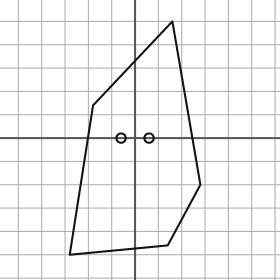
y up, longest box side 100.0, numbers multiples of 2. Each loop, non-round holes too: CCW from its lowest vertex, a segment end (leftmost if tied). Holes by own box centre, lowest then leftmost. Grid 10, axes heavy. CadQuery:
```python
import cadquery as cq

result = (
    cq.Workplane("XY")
    .moveTo(-28.0, -50.0)
    .lineTo(14.0, -46.0)
    .lineTo(28.0, -20.0)
    .lineTo(16.0, 50.0)
    .lineTo(-18.0, 14.0)
    .close()
    .moveTo(-6.0, 0.0)
    .circle(2.0)
    .moveTo(6.0, 0.0)
    .circle(2.0)
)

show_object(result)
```